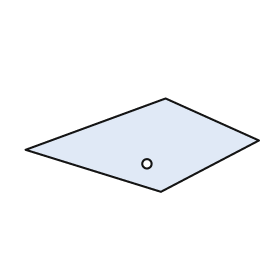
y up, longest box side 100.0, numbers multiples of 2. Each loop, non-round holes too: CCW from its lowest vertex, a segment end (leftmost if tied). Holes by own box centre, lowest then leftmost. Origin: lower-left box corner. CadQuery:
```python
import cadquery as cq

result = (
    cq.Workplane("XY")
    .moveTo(58.0, 0.0)
    .lineTo(100.0, 22.0)
    .lineTo(60.0, 40.0)
    .lineTo(0.0, 18.0)
    .close()
    .moveTo(52.0, 12.0)
    .circle(2.0)
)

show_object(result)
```